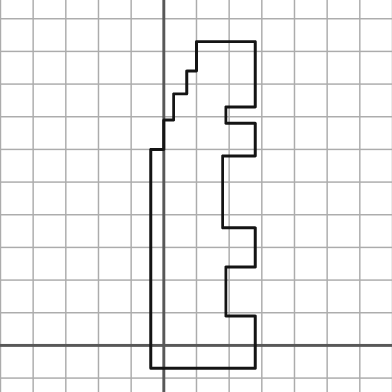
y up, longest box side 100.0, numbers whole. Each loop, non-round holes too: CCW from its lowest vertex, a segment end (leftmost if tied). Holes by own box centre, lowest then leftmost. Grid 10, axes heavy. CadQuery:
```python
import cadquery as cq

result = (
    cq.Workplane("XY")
    .moveTo(-4.0, -7.0)
    .lineTo(28.0, -7.0)
    .lineTo(28.0, 9.0)
    .lineTo(19.0, 9.0)
    .lineTo(19.0, 24.0)
    .lineTo(28.0, 24.0)
    .lineTo(28.0, 36.0)
    .lineTo(18.0, 36.0)
    .lineTo(18.0, 58.0)
    .lineTo(28.0, 58.0)
    .lineTo(28.0, 68.0)
    .lineTo(19.0, 68.0)
    .lineTo(19.0, 73.0)
    .lineTo(28.0, 73.0)
    .lineTo(28.0, 93.0)
    .lineTo(10.0, 93.0)
    .lineTo(10.0, 84.0)
    .lineTo(7.0, 84.0)
    .lineTo(7.0, 77.0)
    .lineTo(3.0, 77.0)
    .lineTo(3.0, 69.0)
    .lineTo(0.0, 69.0)
    .lineTo(0.0, 60.0)
    .lineTo(-4.0, 60.0)
    .close()
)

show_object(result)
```